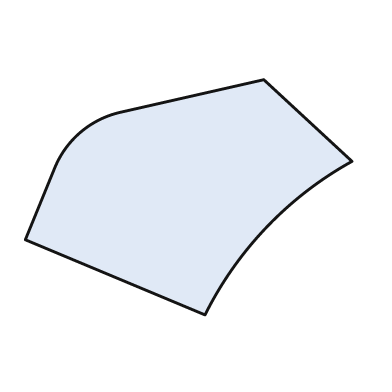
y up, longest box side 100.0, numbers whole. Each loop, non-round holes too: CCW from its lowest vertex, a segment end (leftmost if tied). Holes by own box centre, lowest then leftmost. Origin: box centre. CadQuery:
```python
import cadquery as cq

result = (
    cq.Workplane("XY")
    .moveTo(5.0, -36.0)
    .threePointArc((24.0, -9.0), (50.0, 11.0))
    .lineTo(23.0, 36.0)
    .lineTo(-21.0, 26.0)
    .threePointArc((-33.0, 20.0), (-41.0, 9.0))
    .lineTo(-50.0, -13.0)
    .close()
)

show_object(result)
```